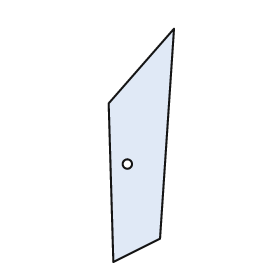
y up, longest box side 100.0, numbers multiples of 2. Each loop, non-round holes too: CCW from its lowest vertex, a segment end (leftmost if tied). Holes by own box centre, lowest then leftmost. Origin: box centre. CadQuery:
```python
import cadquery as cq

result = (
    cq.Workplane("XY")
    .moveTo(-12.0, -50.0)
    .lineTo(8.0, -40.0)
    .lineTo(14.0, 50.0)
    .lineTo(-14.0, 18.0)
    .close()
    .moveTo(-6.0, -8.0)
    .circle(2.0)
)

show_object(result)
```